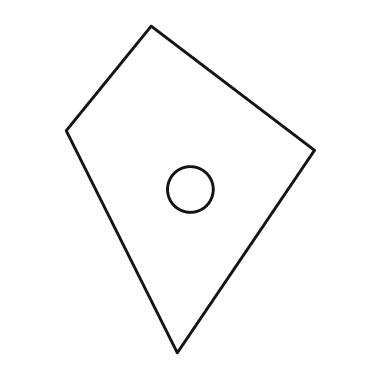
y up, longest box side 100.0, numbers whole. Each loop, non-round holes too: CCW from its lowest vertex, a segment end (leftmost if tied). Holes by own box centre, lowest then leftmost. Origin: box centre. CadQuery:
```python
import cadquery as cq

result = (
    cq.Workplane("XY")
    .moveTo(-4.0, -50.0)
    .lineTo(38.0, 12.0)
    .lineTo(-12.0, 50.0)
    .lineTo(-38.0, 18.0)
    .close()
    .moveTo(0.0, 0.0)
    .circle(7.0)
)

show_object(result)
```